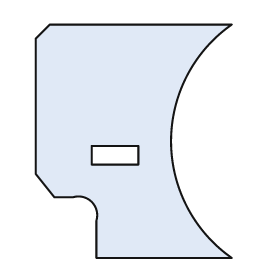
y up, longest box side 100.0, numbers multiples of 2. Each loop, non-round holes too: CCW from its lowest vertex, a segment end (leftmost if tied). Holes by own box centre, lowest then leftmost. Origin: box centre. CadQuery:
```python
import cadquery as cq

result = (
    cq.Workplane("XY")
    .moveTo(-16.0, -50.0)
    .lineTo(42.0, -50.0)
    .threePointArc((16.0, 0.0), (42.0, 50.0))
    .lineTo(-36.0, 50.0)
    .lineTo(-42.0, 44.0)
    .lineTo(-42.0, -14.0)
    .lineTo(-34.0, -24.0)
    .lineTo(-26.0, -24.0)
    .threePointArc((-18.0, -26.0), (-16.0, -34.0))
    .close()
    .moveTo(-18.0, -10.0)
    .lineTo(2.0, -10.0)
    .lineTo(2.0, -2.0)
    .lineTo(-18.0, -2.0)
    .close()
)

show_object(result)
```